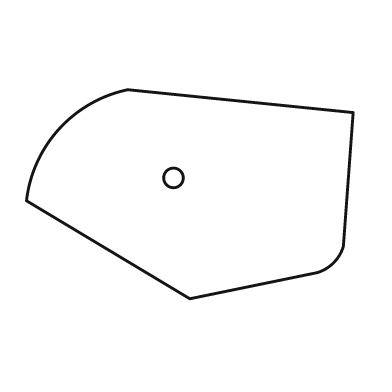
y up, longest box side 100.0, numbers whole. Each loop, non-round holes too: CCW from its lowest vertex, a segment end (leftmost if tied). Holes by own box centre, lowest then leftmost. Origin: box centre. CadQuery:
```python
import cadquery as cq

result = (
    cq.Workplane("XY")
    .moveTo(0.0, -32.0)
    .lineTo(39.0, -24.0)
    .threePointArc((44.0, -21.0), (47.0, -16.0))
    .lineTo(50.0, 25.0)
    .lineTo(-19.0, 32.0)
    .threePointArc((-40.0, 20.0), (-50.0, -2.0))
    .close()
    .moveTo(-5.0, 5.0)
    .circle(3.0)
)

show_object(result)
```